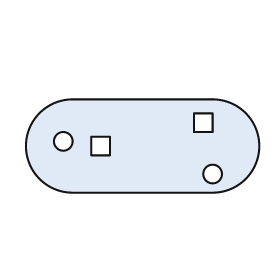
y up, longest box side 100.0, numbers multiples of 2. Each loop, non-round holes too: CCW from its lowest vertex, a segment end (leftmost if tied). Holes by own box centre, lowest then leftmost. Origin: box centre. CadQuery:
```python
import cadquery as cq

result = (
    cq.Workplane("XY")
    .moveTo(-30.0, -20.0)
    .lineTo(30.0, -20.0)
    .threePointArc((50.0, 0.0), (30.0, 20.0))
    .lineTo(-30.0, 20.0)
    .threePointArc((-50.0, 0.0), (-30.0, -20.0))
    .close()
    .moveTo(30.0, -12.0)
    .circle(4.0)
    .moveTo(-22.0, -4.0)
    .lineTo(-14.0, -4.0)
    .lineTo(-14.0, 4.0)
    .lineTo(-22.0, 4.0)
    .close()
    .moveTo(-34.0, 2.0)
    .circle(4.0)
    .moveTo(22.0, 6.0)
    .lineTo(30.0, 6.0)
    .lineTo(30.0, 14.0)
    .lineTo(22.0, 14.0)
    .close()
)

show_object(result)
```